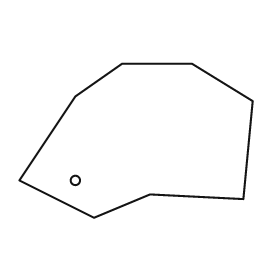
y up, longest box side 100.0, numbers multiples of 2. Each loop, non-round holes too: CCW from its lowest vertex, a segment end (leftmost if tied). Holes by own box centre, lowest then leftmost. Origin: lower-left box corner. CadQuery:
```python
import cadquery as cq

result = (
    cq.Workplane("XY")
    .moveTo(32.0, 0.0)
    .lineTo(56.0, 10.0)
    .lineTo(96.0, 8.0)
    .lineTo(100.0, 50.0)
    .lineTo(74.0, 66.0)
    .lineTo(44.0, 66.0)
    .lineTo(24.0, 52.0)
    .lineTo(0.0, 16.0)
    .close()
    .moveTo(24.0, 16.0)
    .circle(2.0)
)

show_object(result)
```